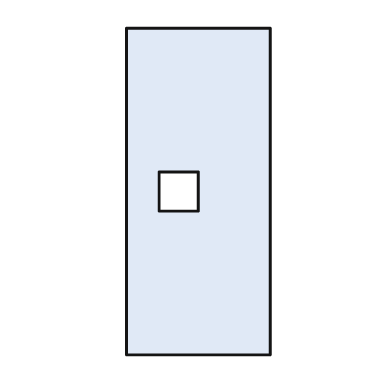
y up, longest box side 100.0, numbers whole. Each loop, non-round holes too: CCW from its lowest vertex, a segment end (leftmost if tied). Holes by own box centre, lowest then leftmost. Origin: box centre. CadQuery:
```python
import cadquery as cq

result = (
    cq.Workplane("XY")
    .moveTo(-22.0, -50.0)
    .lineTo(22.0, -50.0)
    .lineTo(22.0, 50.0)
    .lineTo(-22.0, 50.0)
    .close()
    .moveTo(-12.0, -6.0)
    .lineTo(0.0, -6.0)
    .lineTo(0.0, 6.0)
    .lineTo(-12.0, 6.0)
    .close()
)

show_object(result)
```